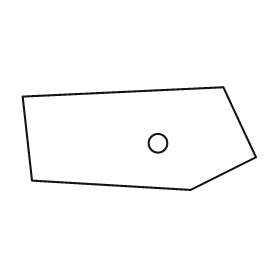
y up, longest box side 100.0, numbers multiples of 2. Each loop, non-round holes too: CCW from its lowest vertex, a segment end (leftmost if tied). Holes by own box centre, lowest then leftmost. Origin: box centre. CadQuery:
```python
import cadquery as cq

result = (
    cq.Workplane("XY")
    .moveTo(22.0, -22.0)
    .lineTo(50.0, -8.0)
    .lineTo(36.0, 22.0)
    .lineTo(-50.0, 18.0)
    .lineTo(-46.0, -18.0)
    .close()
    .moveTo(8.0, -2.0)
    .circle(4.0)
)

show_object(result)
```